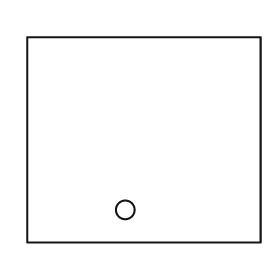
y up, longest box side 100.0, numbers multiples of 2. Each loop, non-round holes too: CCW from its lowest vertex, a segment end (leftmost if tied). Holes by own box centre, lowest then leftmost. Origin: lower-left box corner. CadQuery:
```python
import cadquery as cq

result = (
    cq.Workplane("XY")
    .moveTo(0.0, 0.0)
    .lineTo(100.0, 0.0)
    .lineTo(100.0, 88.0)
    .lineTo(0.0, 88.0)
    .close()
    .moveTo(42.0, 14.0)
    .circle(4.0)
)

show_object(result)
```